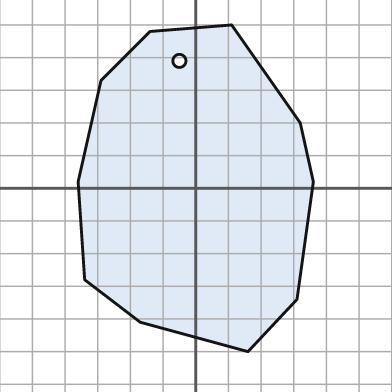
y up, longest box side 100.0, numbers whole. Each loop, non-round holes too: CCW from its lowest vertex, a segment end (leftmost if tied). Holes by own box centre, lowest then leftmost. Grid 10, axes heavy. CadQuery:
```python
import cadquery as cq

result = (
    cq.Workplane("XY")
    .moveTo(16.0, -50.0)
    .lineTo(31.0, -34.0)
    .lineTo(36.0, 2.0)
    .lineTo(32.0, 20.0)
    .lineTo(11.0, 50.0)
    .lineTo(-14.0, 48.0)
    .lineTo(-29.0, 33.0)
    .lineTo(-36.0, 2.0)
    .lineTo(-34.0, -28.0)
    .lineTo(-17.0, -41.0)
    .close()
    .moveTo(-5.0, 39.0)
    .circle(2.0)
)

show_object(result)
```